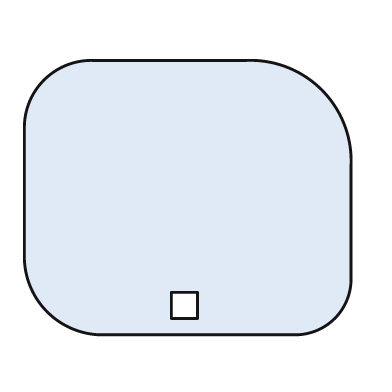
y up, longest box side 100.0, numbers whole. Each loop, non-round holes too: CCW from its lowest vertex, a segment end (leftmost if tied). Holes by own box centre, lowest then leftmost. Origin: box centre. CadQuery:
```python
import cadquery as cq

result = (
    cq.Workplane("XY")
    .moveTo(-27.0, -42.0)
    .lineTo(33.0, -42.0)
    .threePointArc((45.0, -37.0), (50.0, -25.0))
    .lineTo(50.0, 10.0)
    .threePointArc((41.0, 33.0), (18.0, 42.0))
    .lineTo(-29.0, 42.0)
    .threePointArc((-44.0, 36.0), (-50.0, 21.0))
    .lineTo(-50.0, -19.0)
    .threePointArc((-43.0, -35.0), (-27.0, -42.0))
    .close()
    .moveTo(-5.0, -37.0)
    .lineTo(3.0, -37.0)
    .lineTo(3.0, -29.0)
    .lineTo(-5.0, -29.0)
    .close()
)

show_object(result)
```